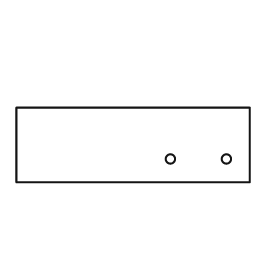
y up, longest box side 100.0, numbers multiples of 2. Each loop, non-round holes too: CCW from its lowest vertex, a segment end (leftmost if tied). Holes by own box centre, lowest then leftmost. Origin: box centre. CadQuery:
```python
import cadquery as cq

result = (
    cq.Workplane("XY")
    .moveTo(-50.0, -16.0)
    .lineTo(50.0, -16.0)
    .lineTo(50.0, 16.0)
    .lineTo(-50.0, 16.0)
    .close()
    .moveTo(16.0, -6.0)
    .circle(2.0)
    .moveTo(40.0, -6.0)
    .circle(2.0)
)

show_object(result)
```